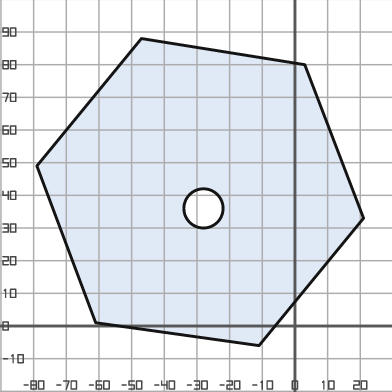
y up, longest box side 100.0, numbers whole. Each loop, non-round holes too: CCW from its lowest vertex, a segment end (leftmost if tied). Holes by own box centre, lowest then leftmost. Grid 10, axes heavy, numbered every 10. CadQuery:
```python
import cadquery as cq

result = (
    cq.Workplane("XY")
    .moveTo(-11.0, -6.0)
    .lineTo(21.0, 33.0)
    .lineTo(3.0, 80.0)
    .lineTo(-47.0, 88.0)
    .lineTo(-79.0, 49.0)
    .lineTo(-61.0, 1.0)
    .close()
    .moveTo(-28.0, 36.0)
    .circle(6.0)
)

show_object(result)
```